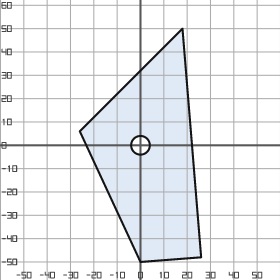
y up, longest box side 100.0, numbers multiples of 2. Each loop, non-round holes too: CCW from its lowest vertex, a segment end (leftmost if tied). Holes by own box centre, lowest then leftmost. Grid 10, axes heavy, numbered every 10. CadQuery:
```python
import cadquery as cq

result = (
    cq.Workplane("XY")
    .moveTo(0.0, -50.0)
    .lineTo(26.0, -48.0)
    .lineTo(18.0, 50.0)
    .lineTo(-26.0, 6.0)
    .close()
    .moveTo(0.0, 0.0)
    .circle(4.0)
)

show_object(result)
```